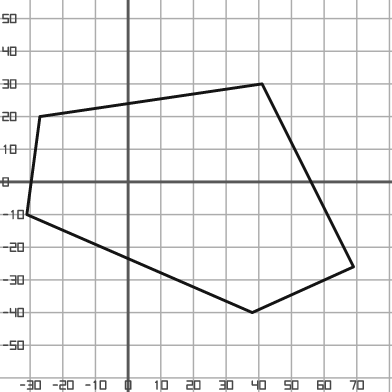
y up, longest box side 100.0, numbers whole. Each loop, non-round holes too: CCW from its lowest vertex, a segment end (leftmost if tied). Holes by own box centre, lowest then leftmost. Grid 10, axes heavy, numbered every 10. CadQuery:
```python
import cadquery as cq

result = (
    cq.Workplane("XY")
    .moveTo(38.0, -40.0)
    .lineTo(69.0, -26.0)
    .lineTo(41.0, 30.0)
    .lineTo(-27.0, 20.0)
    .lineTo(-31.0, -10.0)
    .close()
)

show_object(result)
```